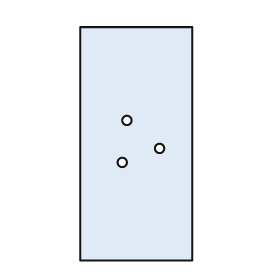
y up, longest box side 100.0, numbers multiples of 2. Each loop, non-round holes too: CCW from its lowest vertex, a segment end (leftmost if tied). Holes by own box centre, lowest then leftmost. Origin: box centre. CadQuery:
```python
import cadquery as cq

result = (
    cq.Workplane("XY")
    .moveTo(-24.0, -50.0)
    .lineTo(24.0, -50.0)
    .lineTo(24.0, 50.0)
    .lineTo(-24.0, 50.0)
    .close()
    .moveTo(-6.0, -8.0)
    .circle(2.0)
    .moveTo(10.0, -2.0)
    .circle(2.0)
    .moveTo(-4.0, 10.0)
    .circle(2.0)
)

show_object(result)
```